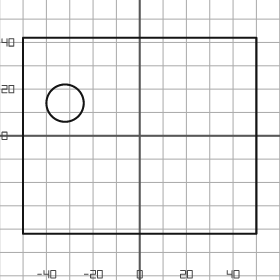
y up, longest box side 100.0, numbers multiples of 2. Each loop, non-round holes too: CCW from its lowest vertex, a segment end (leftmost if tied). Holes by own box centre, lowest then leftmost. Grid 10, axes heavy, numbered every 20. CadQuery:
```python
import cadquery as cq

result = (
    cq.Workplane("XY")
    .moveTo(-50.0, -42.0)
    .lineTo(50.0, -42.0)
    .lineTo(50.0, 42.0)
    .lineTo(-50.0, 42.0)
    .close()
    .moveTo(-32.0, 14.0)
    .circle(8.0)
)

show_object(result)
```